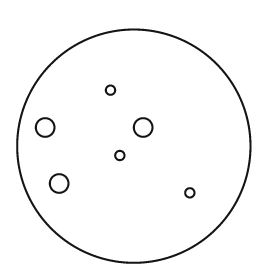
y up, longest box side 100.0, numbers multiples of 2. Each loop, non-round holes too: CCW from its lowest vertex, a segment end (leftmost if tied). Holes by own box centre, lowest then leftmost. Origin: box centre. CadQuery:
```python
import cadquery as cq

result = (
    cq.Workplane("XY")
    .moveTo(0.0, 0.0)
    .circle(50.0)
    .moveTo(24.0, -20.0)
    .circle(2.0)
    .moveTo(-32.0, -16.0)
    .circle(4.0)
    .moveTo(-6.0, -4.0)
    .circle(2.0)
    .moveTo(-38.0, 8.0)
    .circle(4.0)
    .moveTo(4.0, 8.0)
    .circle(4.0)
    .moveTo(-10.0, 24.0)
    .circle(2.0)
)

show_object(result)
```